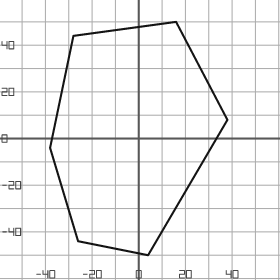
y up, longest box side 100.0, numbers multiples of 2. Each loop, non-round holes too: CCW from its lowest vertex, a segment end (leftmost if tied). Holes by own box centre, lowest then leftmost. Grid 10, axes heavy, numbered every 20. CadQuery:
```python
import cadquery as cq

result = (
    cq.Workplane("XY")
    .moveTo(4.0, -50.0)
    .lineTo(38.0, 8.0)
    .lineTo(16.0, 50.0)
    .lineTo(-28.0, 44.0)
    .lineTo(-38.0, -4.0)
    .lineTo(-26.0, -44.0)
    .close()
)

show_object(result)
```